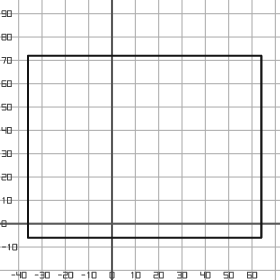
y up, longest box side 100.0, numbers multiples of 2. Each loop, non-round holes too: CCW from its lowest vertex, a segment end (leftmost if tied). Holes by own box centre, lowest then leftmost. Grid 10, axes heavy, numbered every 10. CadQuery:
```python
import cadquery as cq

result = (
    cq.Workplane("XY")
    .moveTo(-36.0, -6.0)
    .lineTo(64.0, -6.0)
    .lineTo(64.0, 72.0)
    .lineTo(-36.0, 72.0)
    .close()
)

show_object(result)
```